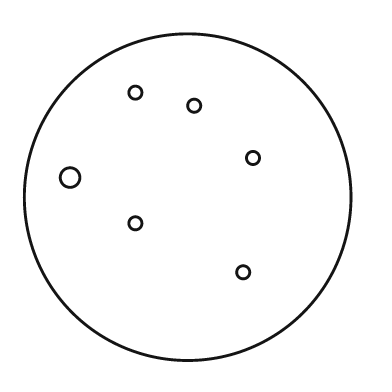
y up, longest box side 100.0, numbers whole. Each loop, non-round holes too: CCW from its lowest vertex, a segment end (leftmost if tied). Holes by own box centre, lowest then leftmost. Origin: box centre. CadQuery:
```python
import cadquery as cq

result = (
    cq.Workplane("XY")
    .moveTo(0.0, 0.0)
    .circle(50.0)
    .moveTo(17.0, -23.0)
    .circle(2.0)
    .moveTo(-16.0, -8.0)
    .circle(2.0)
    .moveTo(-36.0, 6.0)
    .circle(3.0)
    .moveTo(20.0, 12.0)
    .circle(2.0)
    .moveTo(2.0, 28.0)
    .circle(2.0)
    .moveTo(-16.0, 32.0)
    .circle(2.0)
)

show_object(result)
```